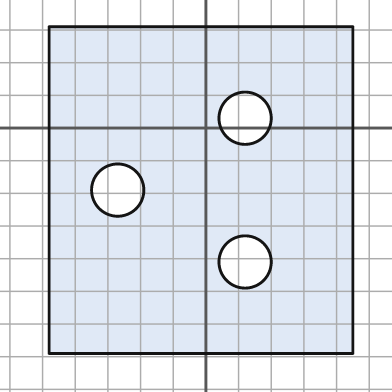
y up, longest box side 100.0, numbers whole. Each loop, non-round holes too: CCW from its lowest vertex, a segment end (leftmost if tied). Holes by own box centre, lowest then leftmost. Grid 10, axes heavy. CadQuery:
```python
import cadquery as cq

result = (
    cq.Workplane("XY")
    .moveTo(-48.0, -69.0)
    .lineTo(45.0, -69.0)
    .lineTo(45.0, 31.0)
    .lineTo(-48.0, 31.0)
    .close()
    .moveTo(12.0, -41.0)
    .circle(8.0)
    .moveTo(-27.0, -19.0)
    .circle(8.0)
    .moveTo(12.0, 3.0)
    .circle(8.0)
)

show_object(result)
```